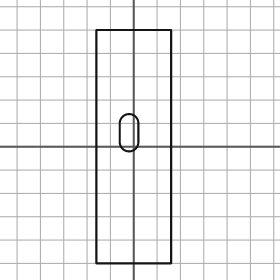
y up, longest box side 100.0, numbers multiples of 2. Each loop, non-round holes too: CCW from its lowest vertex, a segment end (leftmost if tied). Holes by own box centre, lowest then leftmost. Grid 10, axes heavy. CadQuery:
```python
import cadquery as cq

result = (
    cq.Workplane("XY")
    .moveTo(-16.0, -50.0)
    .lineTo(16.0, -50.0)
    .lineTo(16.0, 50.0)
    .lineTo(-16.0, 50.0)
    .close()
    .moveTo(-6.0, 2.0)
    .threePointArc((-2.0, -2.0), (2.0, 2.0))
    .lineTo(2.0, 10.0)
    .threePointArc((-2.0, 14.0), (-6.0, 10.0))
    .close()
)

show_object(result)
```